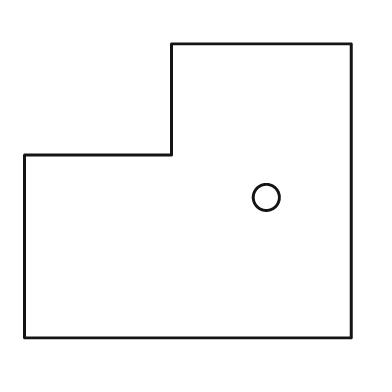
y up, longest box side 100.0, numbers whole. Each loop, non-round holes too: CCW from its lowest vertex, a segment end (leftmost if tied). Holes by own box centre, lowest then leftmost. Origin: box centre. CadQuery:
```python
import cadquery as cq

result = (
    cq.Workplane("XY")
    .moveTo(-50.0, -45.0)
    .lineTo(50.0, -45.0)
    .lineTo(50.0, 45.0)
    .lineTo(-5.0, 45.0)
    .lineTo(-5.0, 11.0)
    .lineTo(-50.0, 11.0)
    .close()
    .moveTo(24.0, -2.0)
    .circle(4.0)
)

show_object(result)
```